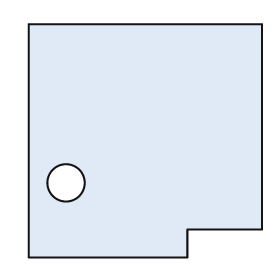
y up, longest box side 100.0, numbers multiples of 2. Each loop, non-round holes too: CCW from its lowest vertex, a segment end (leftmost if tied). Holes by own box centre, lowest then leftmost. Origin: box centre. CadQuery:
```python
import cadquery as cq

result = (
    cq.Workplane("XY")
    .moveTo(-50.0, -50.0)
    .lineTo(18.0, -50.0)
    .lineTo(18.0, -38.0)
    .lineTo(50.0, -38.0)
    .lineTo(50.0, 50.0)
    .lineTo(-50.0, 50.0)
    .close()
    .moveTo(-34.0, -18.0)
    .circle(8.0)
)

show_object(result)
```